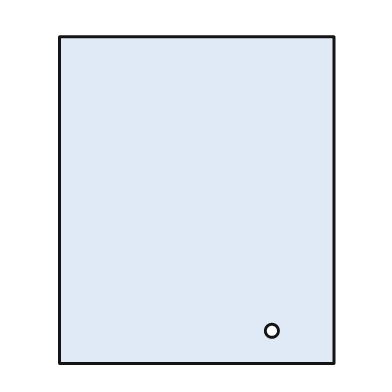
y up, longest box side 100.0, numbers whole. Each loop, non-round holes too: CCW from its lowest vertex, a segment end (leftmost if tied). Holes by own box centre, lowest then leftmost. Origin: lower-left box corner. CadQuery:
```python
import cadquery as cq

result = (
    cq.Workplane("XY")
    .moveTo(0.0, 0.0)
    .lineTo(84.0, 0.0)
    .lineTo(84.0, 100.0)
    .lineTo(0.0, 100.0)
    .close()
    .moveTo(65.0, 10.0)
    .circle(2.0)
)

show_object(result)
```